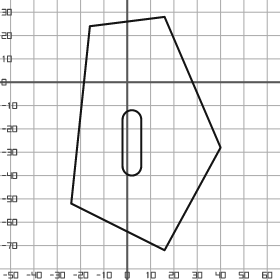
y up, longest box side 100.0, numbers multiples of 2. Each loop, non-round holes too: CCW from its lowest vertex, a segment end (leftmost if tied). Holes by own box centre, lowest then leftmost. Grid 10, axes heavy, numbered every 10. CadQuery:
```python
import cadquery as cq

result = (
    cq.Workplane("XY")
    .moveTo(16.0, -72.0)
    .lineTo(40.0, -28.0)
    .lineTo(16.0, 28.0)
    .lineTo(-16.0, 24.0)
    .lineTo(-24.0, -52.0)
    .close()
    .moveTo(-2.0, -36.0)
    .threePointArc((2.0, -40.0), (6.0, -36.0))
    .lineTo(6.0, -16.0)
    .threePointArc((2.0, -12.0), (-2.0, -16.0))
    .close()
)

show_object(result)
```